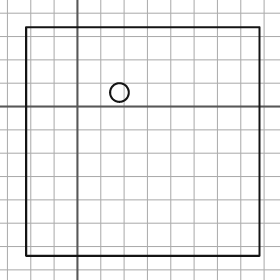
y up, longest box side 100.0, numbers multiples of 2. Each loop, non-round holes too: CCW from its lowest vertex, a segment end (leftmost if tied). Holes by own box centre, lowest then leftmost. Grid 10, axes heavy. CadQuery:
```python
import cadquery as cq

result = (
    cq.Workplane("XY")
    .moveTo(-22.0, -64.0)
    .lineTo(78.0, -64.0)
    .lineTo(78.0, 34.0)
    .lineTo(-22.0, 34.0)
    .close()
    .moveTo(18.0, 6.0)
    .circle(4.0)
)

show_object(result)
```